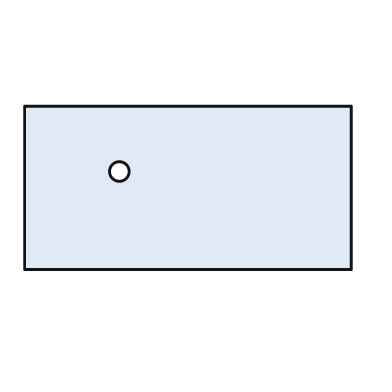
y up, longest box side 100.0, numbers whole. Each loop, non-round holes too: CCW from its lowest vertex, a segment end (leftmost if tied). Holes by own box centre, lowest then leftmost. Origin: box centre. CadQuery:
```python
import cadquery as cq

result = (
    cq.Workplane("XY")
    .moveTo(-50.0, -25.0)
    .lineTo(50.0, -25.0)
    .lineTo(50.0, 25.0)
    .lineTo(-50.0, 25.0)
    .close()
    .moveTo(-21.0, 5.0)
    .circle(3.0)
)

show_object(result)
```